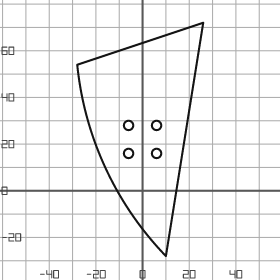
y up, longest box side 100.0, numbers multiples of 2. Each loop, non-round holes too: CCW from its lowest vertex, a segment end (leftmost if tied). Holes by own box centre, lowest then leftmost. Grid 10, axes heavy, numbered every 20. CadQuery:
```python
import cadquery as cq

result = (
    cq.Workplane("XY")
    .moveTo(10.0, -28.0)
    .lineTo(26.0, 72.0)
    .lineTo(-28.0, 54.0)
    .threePointArc((-16.0, 10.0), (10.0, -28.0))
    .close()
    .moveTo(-6.0, 16.0)
    .circle(2.0)
    .moveTo(6.0, 16.0)
    .circle(2.0)
    .moveTo(-6.0, 28.0)
    .circle(2.0)
    .moveTo(6.0, 28.0)
    .circle(2.0)
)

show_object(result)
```